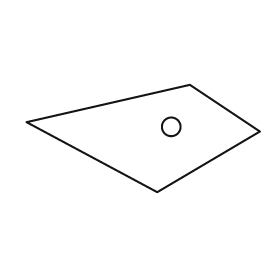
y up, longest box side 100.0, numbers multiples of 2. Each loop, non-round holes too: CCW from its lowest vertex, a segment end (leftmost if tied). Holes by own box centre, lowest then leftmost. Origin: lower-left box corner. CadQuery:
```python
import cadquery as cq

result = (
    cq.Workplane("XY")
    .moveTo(56.0, 0.0)
    .lineTo(100.0, 26.0)
    .lineTo(70.0, 46.0)
    .lineTo(0.0, 30.0)
    .close()
    .moveTo(62.0, 28.0)
    .circle(4.0)
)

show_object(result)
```